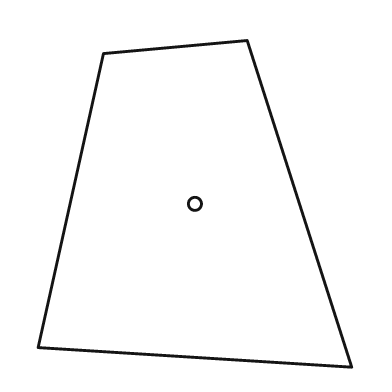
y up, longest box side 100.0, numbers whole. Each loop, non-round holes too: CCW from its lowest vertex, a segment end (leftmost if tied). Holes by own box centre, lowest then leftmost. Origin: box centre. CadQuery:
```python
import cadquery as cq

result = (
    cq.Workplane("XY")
    .moveTo(48.0, -50.0)
    .lineTo(16.0, 50.0)
    .lineTo(-28.0, 46.0)
    .lineTo(-48.0, -44.0)
    .close()
    .moveTo(0.0, 0.0)
    .circle(2.0)
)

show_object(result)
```